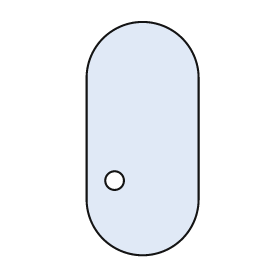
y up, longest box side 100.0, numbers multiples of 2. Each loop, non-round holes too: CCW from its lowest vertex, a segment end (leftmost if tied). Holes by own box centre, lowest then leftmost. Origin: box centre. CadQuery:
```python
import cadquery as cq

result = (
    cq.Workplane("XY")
    .moveTo(-24.0, -26.0)
    .threePointArc((0.0, -50.0), (24.0, -26.0))
    .lineTo(24.0, 26.0)
    .threePointArc((0.0, 50.0), (-24.0, 26.0))
    .close()
    .moveTo(-12.0, -18.0)
    .circle(4.0)
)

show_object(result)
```